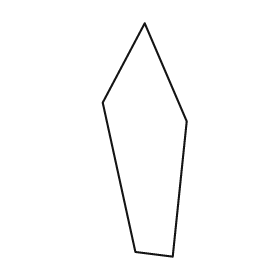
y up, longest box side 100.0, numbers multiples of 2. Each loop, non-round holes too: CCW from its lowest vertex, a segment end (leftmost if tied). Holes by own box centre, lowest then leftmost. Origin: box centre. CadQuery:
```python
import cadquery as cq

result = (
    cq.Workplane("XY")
    .moveTo(12.0, -50.0)
    .lineTo(18.0, 8.0)
    .lineTo(0.0, 50.0)
    .lineTo(-18.0, 16.0)
    .lineTo(-4.0, -48.0)
    .close()
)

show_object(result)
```